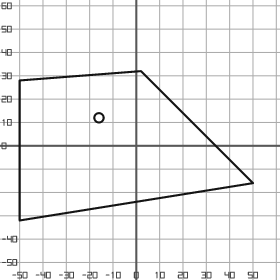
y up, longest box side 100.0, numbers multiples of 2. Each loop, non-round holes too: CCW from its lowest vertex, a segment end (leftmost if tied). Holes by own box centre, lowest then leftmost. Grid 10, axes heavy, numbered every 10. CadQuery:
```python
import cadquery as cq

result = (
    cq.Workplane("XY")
    .moveTo(-50.0, -32.0)
    .lineTo(50.0, -16.0)
    .lineTo(2.0, 32.0)
    .lineTo(-50.0, 28.0)
    .close()
    .moveTo(-16.0, 12.0)
    .circle(2.0)
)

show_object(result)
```